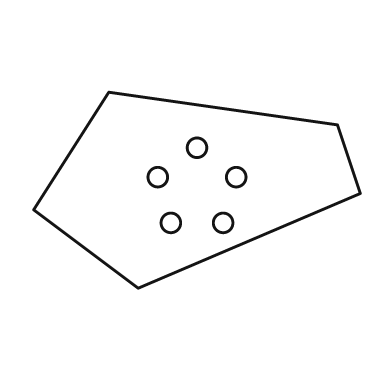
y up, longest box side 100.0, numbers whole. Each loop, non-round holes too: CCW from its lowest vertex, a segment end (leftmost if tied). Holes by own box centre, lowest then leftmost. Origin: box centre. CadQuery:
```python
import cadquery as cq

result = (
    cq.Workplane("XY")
    .moveTo(-18.0, -30.0)
    .lineTo(50.0, -1.0)
    .lineTo(43.0, 20.0)
    .lineTo(-27.0, 30.0)
    .lineTo(-50.0, -6.0)
    .close()
    .moveTo(-8.0, -10.0)
    .circle(3.0)
    .moveTo(8.0, -10.0)
    .circle(3.0)
    .moveTo(-12.0, 4.0)
    .circle(3.0)
    .moveTo(12.0, 4.0)
    .circle(3.0)
    .moveTo(0.0, 13.0)
    .circle(3.0)
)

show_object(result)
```